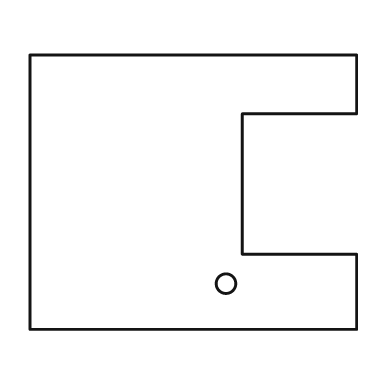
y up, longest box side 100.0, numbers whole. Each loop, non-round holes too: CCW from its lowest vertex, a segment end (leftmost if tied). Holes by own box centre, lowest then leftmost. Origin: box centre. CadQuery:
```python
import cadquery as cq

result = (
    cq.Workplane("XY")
    .moveTo(-50.0, -42.0)
    .lineTo(50.0, -42.0)
    .lineTo(50.0, -19.0)
    .lineTo(15.0, -19.0)
    .lineTo(15.0, 24.0)
    .lineTo(50.0, 24.0)
    .lineTo(50.0, 42.0)
    .lineTo(-50.0, 42.0)
    .close()
    .moveTo(10.0, -28.0)
    .circle(3.0)
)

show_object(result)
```